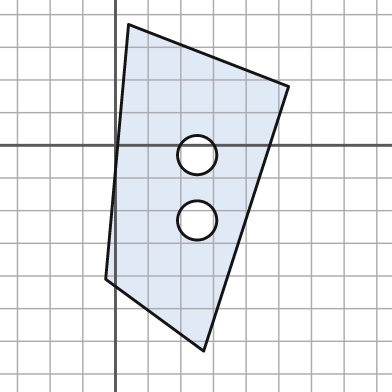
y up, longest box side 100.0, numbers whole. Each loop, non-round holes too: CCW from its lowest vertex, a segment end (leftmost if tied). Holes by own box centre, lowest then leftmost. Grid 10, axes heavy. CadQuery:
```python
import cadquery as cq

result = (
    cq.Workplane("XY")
    .moveTo(27.0, -63.0)
    .lineTo(53.0, 18.0)
    .lineTo(4.0, 37.0)
    .lineTo(-3.0, -41.0)
    .close()
    .moveTo(25.0, -23.0)
    .circle(6.0)
    .moveTo(25.0, -3.0)
    .circle(6.0)
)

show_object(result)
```